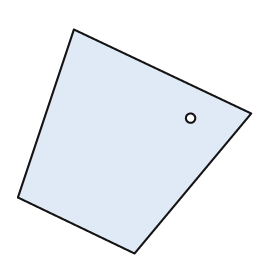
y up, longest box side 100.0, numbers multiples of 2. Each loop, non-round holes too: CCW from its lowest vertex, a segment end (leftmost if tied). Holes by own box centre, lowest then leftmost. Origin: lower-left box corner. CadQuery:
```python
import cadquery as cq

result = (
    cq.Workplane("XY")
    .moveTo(50.0, 0.0)
    .lineTo(100.0, 60.0)
    .lineTo(24.0, 96.0)
    .lineTo(0.0, 24.0)
    .close()
    .moveTo(74.0, 58.0)
    .circle(2.0)
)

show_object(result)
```